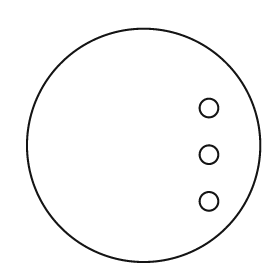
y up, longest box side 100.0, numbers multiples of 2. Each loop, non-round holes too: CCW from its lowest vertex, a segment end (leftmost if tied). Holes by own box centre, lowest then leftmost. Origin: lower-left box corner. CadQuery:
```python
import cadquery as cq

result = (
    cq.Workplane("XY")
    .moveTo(50.0, 50.0)
    .circle(50.0)
    .moveTo(78.0, 26.0)
    .circle(4.0)
    .moveTo(78.0, 46.0)
    .circle(4.0)
    .moveTo(78.0, 66.0)
    .circle(4.0)
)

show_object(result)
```